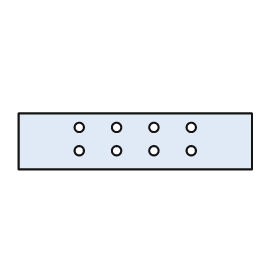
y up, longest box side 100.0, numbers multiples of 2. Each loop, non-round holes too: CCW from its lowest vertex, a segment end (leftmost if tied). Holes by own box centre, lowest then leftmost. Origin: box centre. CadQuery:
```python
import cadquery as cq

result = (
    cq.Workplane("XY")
    .moveTo(-50.0, -12.0)
    .lineTo(50.0, -12.0)
    .lineTo(50.0, 12.0)
    .lineTo(-50.0, 12.0)
    .close()
    .moveTo(-24.0, -4.0)
    .circle(2.0)
    .moveTo(-8.0, -4.0)
    .circle(2.0)
    .moveTo(8.0, -4.0)
    .circle(2.0)
    .moveTo(24.0, -4.0)
    .circle(2.0)
    .moveTo(-24.0, 6.0)
    .circle(2.0)
    .moveTo(-8.0, 6.0)
    .circle(2.0)
    .moveTo(8.0, 6.0)
    .circle(2.0)
    .moveTo(24.0, 6.0)
    .circle(2.0)
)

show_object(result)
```